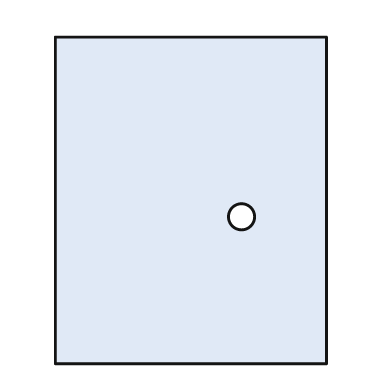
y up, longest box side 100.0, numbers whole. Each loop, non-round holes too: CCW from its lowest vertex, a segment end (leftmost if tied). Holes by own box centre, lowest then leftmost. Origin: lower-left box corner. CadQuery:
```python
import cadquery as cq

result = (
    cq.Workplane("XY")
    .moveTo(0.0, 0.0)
    .lineTo(83.0, 0.0)
    .lineTo(83.0, 100.0)
    .lineTo(0.0, 100.0)
    .close()
    .moveTo(57.0, 45.0)
    .circle(4.0)
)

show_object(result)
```